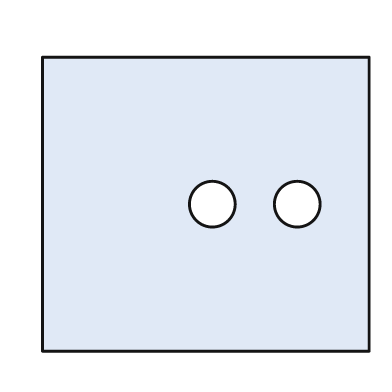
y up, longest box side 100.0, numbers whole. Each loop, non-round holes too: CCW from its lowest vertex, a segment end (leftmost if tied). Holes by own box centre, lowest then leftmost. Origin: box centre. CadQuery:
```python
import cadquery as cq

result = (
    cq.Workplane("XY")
    .moveTo(-50.0, -45.0)
    .lineTo(50.0, -45.0)
    .lineTo(50.0, 45.0)
    .lineTo(-50.0, 45.0)
    .close()
    .moveTo(2.0, 0.0)
    .circle(7.0)
    .moveTo(28.0, 0.0)
    .circle(7.0)
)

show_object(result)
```